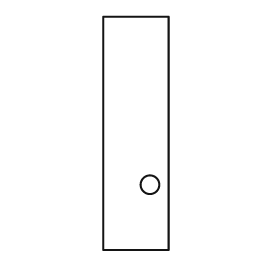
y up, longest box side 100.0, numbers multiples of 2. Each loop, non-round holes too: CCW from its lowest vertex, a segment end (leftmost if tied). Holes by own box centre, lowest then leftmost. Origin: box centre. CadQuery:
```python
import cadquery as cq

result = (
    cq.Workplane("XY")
    .moveTo(-14.0, -50.0)
    .lineTo(14.0, -50.0)
    .lineTo(14.0, 50.0)
    .lineTo(-14.0, 50.0)
    .close()
    .moveTo(6.0, -22.0)
    .circle(4.0)
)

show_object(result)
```